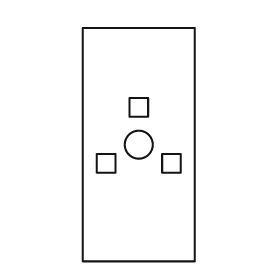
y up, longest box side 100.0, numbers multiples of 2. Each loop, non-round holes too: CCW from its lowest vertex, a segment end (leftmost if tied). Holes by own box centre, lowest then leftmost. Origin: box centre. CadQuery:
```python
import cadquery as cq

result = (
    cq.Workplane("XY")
    .moveTo(-24.0, -50.0)
    .lineTo(24.0, -50.0)
    .lineTo(24.0, 50.0)
    .lineTo(-24.0, 50.0)
    .close()
    .moveTo(-18.0, -12.0)
    .lineTo(-10.0, -12.0)
    .lineTo(-10.0, -4.0)
    .lineTo(-18.0, -4.0)
    .close()
    .moveTo(10.0, -12.0)
    .lineTo(18.0, -12.0)
    .lineTo(18.0, -4.0)
    .lineTo(10.0, -4.0)
    .close()
    .moveTo(0.0, 0.0)
    .circle(6.0)
    .moveTo(-4.0, 12.0)
    .lineTo(4.0, 12.0)
    .lineTo(4.0, 20.0)
    .lineTo(-4.0, 20.0)
    .close()
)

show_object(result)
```